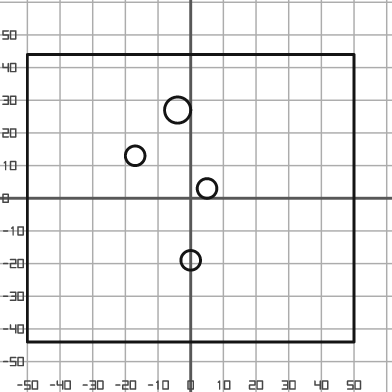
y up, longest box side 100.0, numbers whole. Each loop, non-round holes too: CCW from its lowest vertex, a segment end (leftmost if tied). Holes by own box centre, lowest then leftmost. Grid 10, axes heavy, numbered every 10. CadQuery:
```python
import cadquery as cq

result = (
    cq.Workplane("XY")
    .moveTo(-50.0, -44.0)
    .lineTo(50.0, -44.0)
    .lineTo(50.0, 44.0)
    .lineTo(-50.0, 44.0)
    .close()
    .moveTo(0.0, -19.0)
    .circle(3.0)
    .moveTo(5.0, 3.0)
    .circle(3.0)
    .moveTo(-17.0, 13.0)
    .circle(3.0)
    .moveTo(-4.0, 27.0)
    .circle(4.0)
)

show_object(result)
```